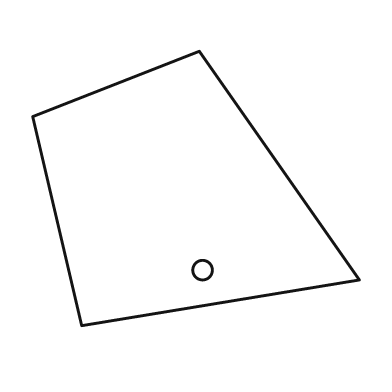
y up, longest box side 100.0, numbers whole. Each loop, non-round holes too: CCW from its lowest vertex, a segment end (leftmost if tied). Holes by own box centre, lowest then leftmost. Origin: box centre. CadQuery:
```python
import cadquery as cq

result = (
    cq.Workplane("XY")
    .moveTo(-35.0, -42.0)
    .lineTo(50.0, -28.0)
    .lineTo(1.0, 42.0)
    .lineTo(-50.0, 22.0)
    .close()
    .moveTo(2.0, -25.0)
    .circle(3.0)
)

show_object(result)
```